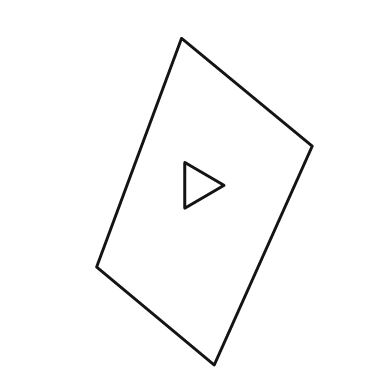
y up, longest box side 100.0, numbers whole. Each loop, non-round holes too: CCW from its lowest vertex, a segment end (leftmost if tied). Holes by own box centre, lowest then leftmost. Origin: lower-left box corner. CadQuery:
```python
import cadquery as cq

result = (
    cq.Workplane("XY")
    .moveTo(36.0, 0.0)
    .lineTo(66.0, 67.0)
    .lineTo(26.0, 100.0)
    .lineTo(0.0, 30.0)
    .close()
    .moveTo(27.0, 48.0)
    .lineTo(39.0, 55.0)
    .lineTo(27.0, 62.0)
    .close()
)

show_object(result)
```